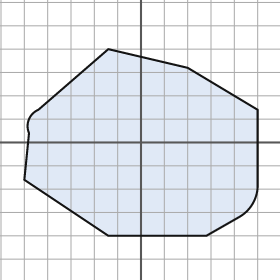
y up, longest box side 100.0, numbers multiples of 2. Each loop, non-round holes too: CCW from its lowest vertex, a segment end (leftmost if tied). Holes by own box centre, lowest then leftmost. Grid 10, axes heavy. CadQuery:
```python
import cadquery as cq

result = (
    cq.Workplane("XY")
    .moveTo(-14.0, -40.0)
    .lineTo(28.0, -40.0)
    .lineTo(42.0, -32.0)
    .threePointArc((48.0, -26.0), (50.0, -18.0))
    .lineTo(50.0, 14.0)
    .lineTo(20.0, 32.0)
    .lineTo(-14.0, 40.0)
    .lineTo(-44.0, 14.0)
    .threePointArc((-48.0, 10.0), (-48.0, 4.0))
    .lineTo(-50.0, -16.0)
    .close()
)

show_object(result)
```